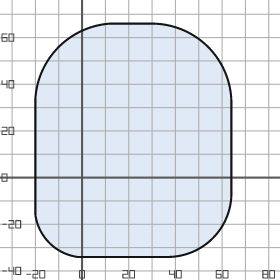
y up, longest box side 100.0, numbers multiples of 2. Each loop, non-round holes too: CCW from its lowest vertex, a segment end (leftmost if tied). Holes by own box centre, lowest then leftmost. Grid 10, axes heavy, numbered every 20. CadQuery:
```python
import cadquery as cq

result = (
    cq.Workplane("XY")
    .moveTo(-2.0, -34.0)
    .lineTo(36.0, -34.0)
    .threePointArc((56.0, -26.0), (64.0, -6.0))
    .lineTo(64.0, 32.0)
    .threePointArc((54.0, 56.0), (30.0, 66.0))
    .lineTo(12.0, 66.0)
    .threePointArc((-10.0, 56.0), (-20.0, 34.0))
    .lineTo(-20.0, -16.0)
    .threePointArc((-14.0, -28.0), (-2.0, -34.0))
    .close()
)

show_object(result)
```